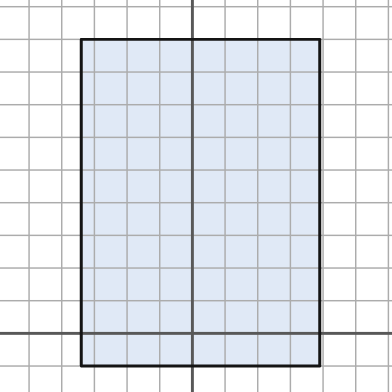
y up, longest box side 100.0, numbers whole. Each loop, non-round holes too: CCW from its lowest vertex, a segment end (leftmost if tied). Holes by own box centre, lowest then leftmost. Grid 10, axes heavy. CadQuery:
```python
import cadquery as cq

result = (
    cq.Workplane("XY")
    .moveTo(-34.0, -10.0)
    .lineTo(39.0, -10.0)
    .lineTo(39.0, 90.0)
    .lineTo(-34.0, 90.0)
    .close()
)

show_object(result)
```